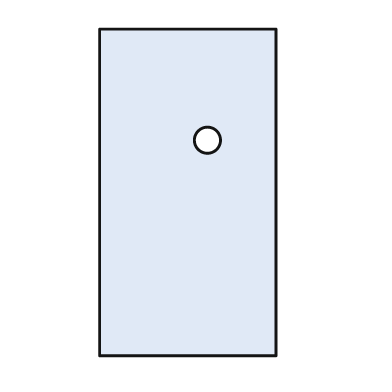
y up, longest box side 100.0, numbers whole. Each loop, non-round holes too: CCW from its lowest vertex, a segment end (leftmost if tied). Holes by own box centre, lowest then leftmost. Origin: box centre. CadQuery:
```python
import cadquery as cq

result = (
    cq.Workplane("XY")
    .moveTo(-27.0, -50.0)
    .lineTo(27.0, -50.0)
    .lineTo(27.0, 50.0)
    .lineTo(-27.0, 50.0)
    .close()
    .moveTo(6.0, 16.0)
    .circle(4.0)
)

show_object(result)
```